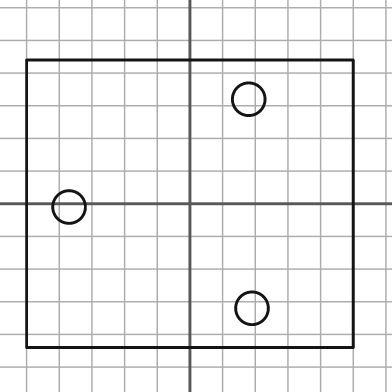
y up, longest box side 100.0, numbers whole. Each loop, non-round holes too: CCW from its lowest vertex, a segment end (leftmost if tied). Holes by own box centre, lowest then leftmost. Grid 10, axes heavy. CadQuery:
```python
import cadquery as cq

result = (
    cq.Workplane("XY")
    .moveTo(-50.0, -44.0)
    .lineTo(50.0, -44.0)
    .lineTo(50.0, 44.0)
    .lineTo(-50.0, 44.0)
    .close()
    .moveTo(19.0, -32.0)
    .circle(5.0)
    .moveTo(-37.0, -1.0)
    .circle(5.0)
    .moveTo(18.0, 32.0)
    .circle(5.0)
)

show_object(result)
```